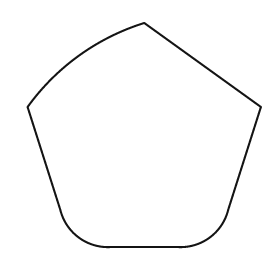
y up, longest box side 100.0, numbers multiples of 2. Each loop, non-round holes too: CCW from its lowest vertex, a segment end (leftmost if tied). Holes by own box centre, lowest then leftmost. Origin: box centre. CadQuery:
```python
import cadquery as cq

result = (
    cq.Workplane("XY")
    .moveTo(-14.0, -48.0)
    .lineTo(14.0, -48.0)
    .threePointArc((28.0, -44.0), (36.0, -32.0))
    .lineTo(50.0, 12.0)
    .lineTo(0.0, 48.0)
    .threePointArc((-28.0, 34.0), (-50.0, 12.0))
    .lineTo(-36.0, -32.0)
    .threePointArc((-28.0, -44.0), (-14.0, -48.0))
    .close()
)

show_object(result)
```